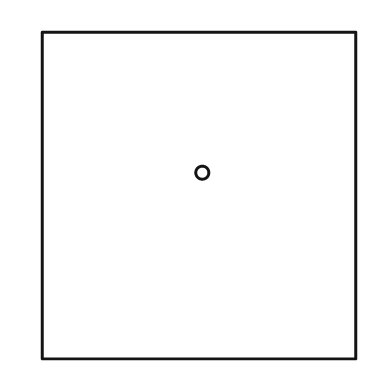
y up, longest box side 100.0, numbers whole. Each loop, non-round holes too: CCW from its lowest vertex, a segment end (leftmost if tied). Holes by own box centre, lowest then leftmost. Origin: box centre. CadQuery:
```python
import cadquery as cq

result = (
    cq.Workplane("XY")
    .moveTo(-48.0, -50.0)
    .lineTo(48.0, -50.0)
    .lineTo(48.0, 50.0)
    .lineTo(-48.0, 50.0)
    .close()
    .moveTo(1.0, 7.0)
    .circle(2.0)
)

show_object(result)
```